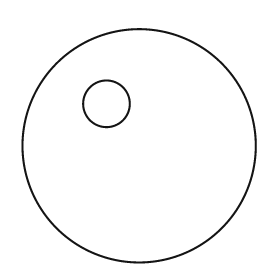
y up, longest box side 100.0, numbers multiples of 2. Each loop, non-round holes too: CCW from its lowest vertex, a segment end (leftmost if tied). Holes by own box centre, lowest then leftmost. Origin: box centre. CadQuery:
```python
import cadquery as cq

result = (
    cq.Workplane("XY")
    .moveTo(0.0, 0.0)
    .circle(50.0)
    .moveTo(-14.0, 18.0)
    .circle(10.0)
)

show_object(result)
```